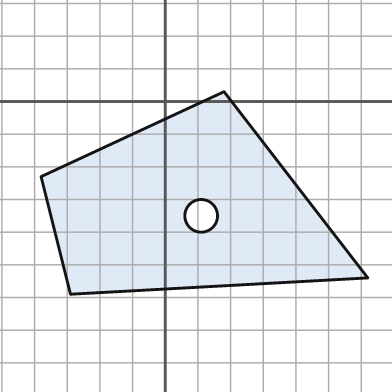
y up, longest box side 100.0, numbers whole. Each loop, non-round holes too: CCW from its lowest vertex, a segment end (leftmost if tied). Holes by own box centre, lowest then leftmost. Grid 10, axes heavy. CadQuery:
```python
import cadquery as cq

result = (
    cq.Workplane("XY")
    .moveTo(-29.0, -59.0)
    .lineTo(62.0, -54.0)
    .lineTo(18.0, 3.0)
    .lineTo(-38.0, -23.0)
    .close()
    .moveTo(11.0, -35.0)
    .circle(5.0)
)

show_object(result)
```